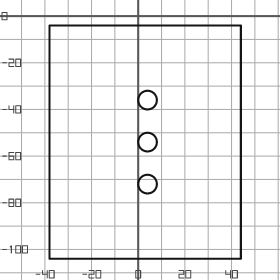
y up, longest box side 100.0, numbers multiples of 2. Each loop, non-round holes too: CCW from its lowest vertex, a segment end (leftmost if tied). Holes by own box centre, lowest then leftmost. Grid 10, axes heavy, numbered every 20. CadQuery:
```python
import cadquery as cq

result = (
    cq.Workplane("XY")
    .moveTo(-38.0, -104.0)
    .lineTo(44.0, -104.0)
    .lineTo(44.0, -4.0)
    .lineTo(-38.0, -4.0)
    .close()
    .moveTo(4.0, -72.0)
    .circle(4.0)
    .moveTo(4.0, -54.0)
    .circle(4.0)
    .moveTo(4.0, -36.0)
    .circle(4.0)
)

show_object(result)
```